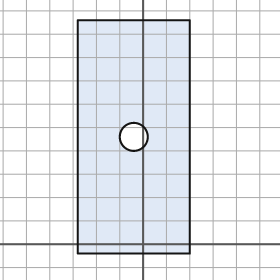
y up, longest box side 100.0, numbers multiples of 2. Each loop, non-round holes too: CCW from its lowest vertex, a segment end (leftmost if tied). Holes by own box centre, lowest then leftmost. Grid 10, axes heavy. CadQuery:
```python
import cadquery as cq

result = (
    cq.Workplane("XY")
    .moveTo(-28.0, -4.0)
    .lineTo(20.0, -4.0)
    .lineTo(20.0, 96.0)
    .lineTo(-28.0, 96.0)
    .close()
    .moveTo(-4.0, 46.0)
    .circle(6.0)
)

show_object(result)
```